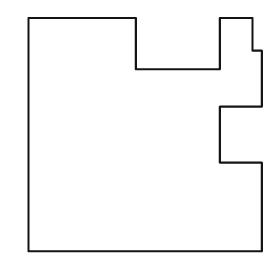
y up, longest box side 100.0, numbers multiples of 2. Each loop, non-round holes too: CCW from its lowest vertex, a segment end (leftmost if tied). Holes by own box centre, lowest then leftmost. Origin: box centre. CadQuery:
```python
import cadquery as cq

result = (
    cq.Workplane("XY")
    .moveTo(-50.0, -50.0)
    .lineTo(50.0, -50.0)
    .lineTo(50.0, -12.0)
    .lineTo(32.0, -12.0)
    .lineTo(32.0, 12.0)
    .lineTo(50.0, 12.0)
    .lineTo(50.0, 36.0)
    .lineTo(46.0, 36.0)
    .lineTo(46.0, 50.0)
    .lineTo(32.0, 50.0)
    .lineTo(32.0, 28.0)
    .lineTo(-4.0, 28.0)
    .lineTo(-4.0, 50.0)
    .lineTo(-50.0, 50.0)
    .close()
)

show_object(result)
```